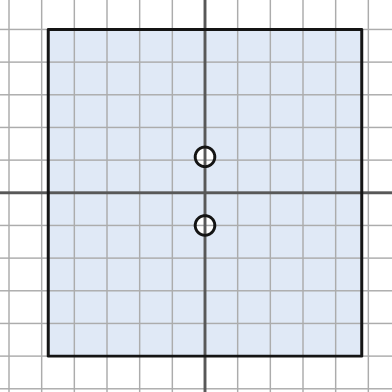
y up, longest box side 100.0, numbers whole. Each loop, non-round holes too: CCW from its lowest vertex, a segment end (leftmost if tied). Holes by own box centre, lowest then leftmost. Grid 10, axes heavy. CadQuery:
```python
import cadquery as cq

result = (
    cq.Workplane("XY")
    .moveTo(-48.0, -50.0)
    .lineTo(48.0, -50.0)
    .lineTo(48.0, 50.0)
    .lineTo(-48.0, 50.0)
    .close()
    .moveTo(0.0, -10.0)
    .circle(3.0)
    .moveTo(0.0, 11.0)
    .circle(3.0)
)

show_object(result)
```